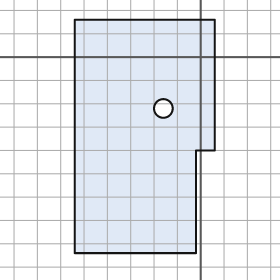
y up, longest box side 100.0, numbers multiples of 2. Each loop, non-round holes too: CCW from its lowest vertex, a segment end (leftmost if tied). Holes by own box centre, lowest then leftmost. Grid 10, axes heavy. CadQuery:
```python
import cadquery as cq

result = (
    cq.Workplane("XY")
    .moveTo(-54.0, -84.0)
    .lineTo(-2.0, -84.0)
    .lineTo(-2.0, -40.0)
    .lineTo(6.0, -40.0)
    .lineTo(6.0, 16.0)
    .lineTo(-54.0, 16.0)
    .close()
    .moveTo(-16.0, -22.0)
    .circle(4.0)
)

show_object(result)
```